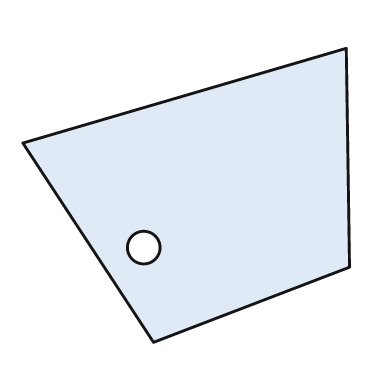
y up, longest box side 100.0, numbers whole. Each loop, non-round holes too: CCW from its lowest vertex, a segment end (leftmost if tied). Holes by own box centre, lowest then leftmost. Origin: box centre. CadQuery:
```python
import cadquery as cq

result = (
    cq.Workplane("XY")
    .moveTo(-10.0, -45.0)
    .lineTo(50.0, -22.0)
    .lineTo(49.0, 45.0)
    .lineTo(-50.0, 16.0)
    .close()
    .moveTo(-13.0, -16.0)
    .circle(5.0)
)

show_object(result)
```